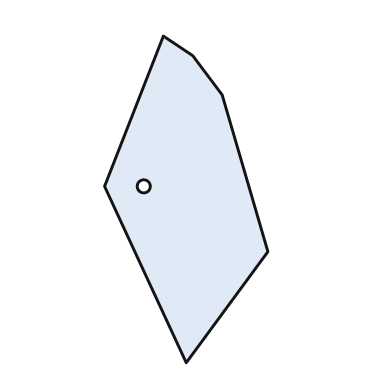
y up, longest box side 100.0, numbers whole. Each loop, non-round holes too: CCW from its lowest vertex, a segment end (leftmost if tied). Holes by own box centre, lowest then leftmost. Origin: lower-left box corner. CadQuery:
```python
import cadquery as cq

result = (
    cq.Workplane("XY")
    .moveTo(25.0, 0.0)
    .lineTo(50.0, 34.0)
    .lineTo(36.0, 82.0)
    .lineTo(27.0, 94.0)
    .lineTo(18.0, 100.0)
    .lineTo(0.0, 54.0)
    .close()
    .moveTo(12.0, 54.0)
    .circle(2.0)
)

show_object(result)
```